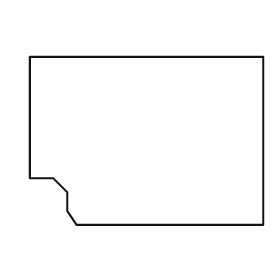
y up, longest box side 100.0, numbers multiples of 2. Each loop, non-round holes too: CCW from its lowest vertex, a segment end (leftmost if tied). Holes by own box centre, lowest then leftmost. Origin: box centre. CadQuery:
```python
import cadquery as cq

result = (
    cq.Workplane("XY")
    .moveTo(-30.0, -36.0)
    .lineTo(50.0, -36.0)
    .lineTo(50.0, 36.0)
    .lineTo(-50.0, 36.0)
    .lineTo(-50.0, -16.0)
    .lineTo(-40.0, -16.0)
    .lineTo(-34.0, -22.0)
    .lineTo(-34.0, -30.0)
    .close()
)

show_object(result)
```